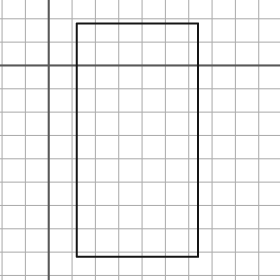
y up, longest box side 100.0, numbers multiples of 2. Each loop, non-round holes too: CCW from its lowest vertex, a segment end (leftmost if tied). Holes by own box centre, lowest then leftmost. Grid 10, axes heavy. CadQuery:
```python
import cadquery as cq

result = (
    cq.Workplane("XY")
    .moveTo(12.0, -82.0)
    .lineTo(64.0, -82.0)
    .lineTo(64.0, 18.0)
    .lineTo(12.0, 18.0)
    .close()
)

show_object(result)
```